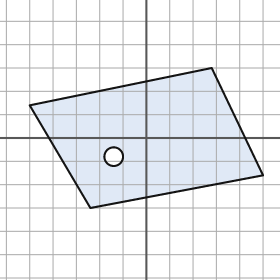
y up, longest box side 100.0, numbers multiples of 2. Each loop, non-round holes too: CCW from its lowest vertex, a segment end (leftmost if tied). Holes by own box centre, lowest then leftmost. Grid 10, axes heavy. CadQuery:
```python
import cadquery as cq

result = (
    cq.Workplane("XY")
    .moveTo(-24.0, -30.0)
    .lineTo(50.0, -16.0)
    .lineTo(28.0, 30.0)
    .lineTo(-50.0, 14.0)
    .close()
    .moveTo(-14.0, -8.0)
    .circle(4.0)
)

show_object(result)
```